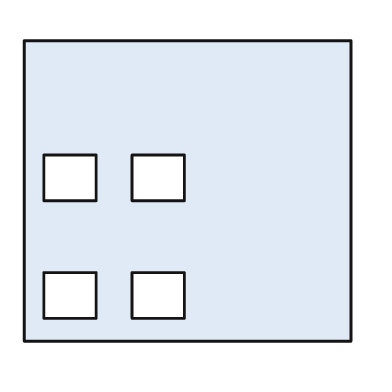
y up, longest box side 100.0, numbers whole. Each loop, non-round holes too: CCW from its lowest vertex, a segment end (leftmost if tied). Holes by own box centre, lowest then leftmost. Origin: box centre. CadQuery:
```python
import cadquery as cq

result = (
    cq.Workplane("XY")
    .moveTo(-50.0, -46.0)
    .lineTo(50.0, -46.0)
    .lineTo(50.0, 46.0)
    .lineTo(-50.0, 46.0)
    .close()
    .moveTo(-44.0, -39.0)
    .lineTo(-28.0, -39.0)
    .lineTo(-28.0, -25.0)
    .lineTo(-44.0, -25.0)
    .close()
    .moveTo(-17.0, -39.0)
    .lineTo(-1.0, -39.0)
    .lineTo(-1.0, -25.0)
    .lineTo(-17.0, -25.0)
    .close()
    .moveTo(-44.0, -3.0)
    .lineTo(-28.0, -3.0)
    .lineTo(-28.0, 11.0)
    .lineTo(-44.0, 11.0)
    .close()
    .moveTo(-17.0, -3.0)
    .lineTo(-1.0, -3.0)
    .lineTo(-1.0, 11.0)
    .lineTo(-17.0, 11.0)
    .close()
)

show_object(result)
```